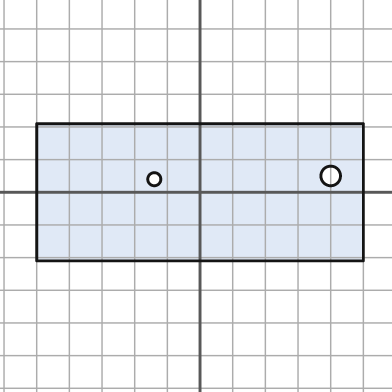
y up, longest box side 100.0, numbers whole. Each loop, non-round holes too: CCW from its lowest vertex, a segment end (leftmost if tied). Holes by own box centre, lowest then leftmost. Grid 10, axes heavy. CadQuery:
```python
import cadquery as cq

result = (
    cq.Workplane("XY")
    .moveTo(-50.0, -21.0)
    .lineTo(50.0, -21.0)
    .lineTo(50.0, 21.0)
    .lineTo(-50.0, 21.0)
    .close()
    .moveTo(-14.0, 4.0)
    .circle(2.0)
    .moveTo(40.0, 5.0)
    .circle(3.0)
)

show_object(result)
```